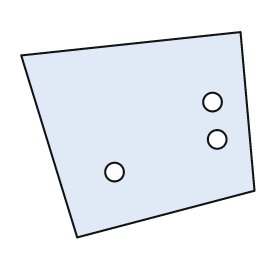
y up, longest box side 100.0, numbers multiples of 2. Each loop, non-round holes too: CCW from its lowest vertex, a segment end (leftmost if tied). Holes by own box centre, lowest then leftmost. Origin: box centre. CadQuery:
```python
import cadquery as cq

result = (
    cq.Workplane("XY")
    .moveTo(-26.0, -44.0)
    .lineTo(50.0, -24.0)
    .lineTo(44.0, 44.0)
    .lineTo(-50.0, 34.0)
    .close()
    .moveTo(-10.0, -16.0)
    .circle(4.0)
    .moveTo(34.0, -2.0)
    .circle(4.0)
    .moveTo(32.0, 14.0)
    .circle(4.0)
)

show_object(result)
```